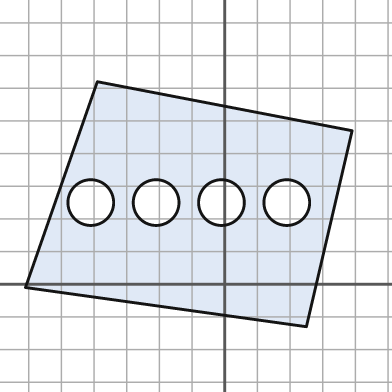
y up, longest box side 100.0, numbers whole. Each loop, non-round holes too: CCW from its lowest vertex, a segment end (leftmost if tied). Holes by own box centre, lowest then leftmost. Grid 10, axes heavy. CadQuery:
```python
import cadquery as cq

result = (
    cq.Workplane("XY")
    .moveTo(25.0, -13.0)
    .lineTo(39.0, 47.0)
    .lineTo(-39.0, 62.0)
    .lineTo(-61.0, -1.0)
    .close()
    .moveTo(-41.0, 25.0)
    .circle(7.0)
    .moveTo(-21.0, 25.0)
    .circle(7.0)
    .moveTo(-1.0, 25.0)
    .circle(7.0)
    .moveTo(19.0, 25.0)
    .circle(7.0)
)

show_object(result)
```